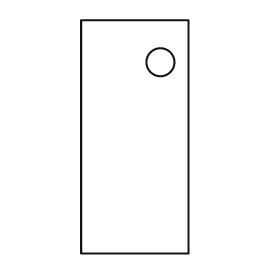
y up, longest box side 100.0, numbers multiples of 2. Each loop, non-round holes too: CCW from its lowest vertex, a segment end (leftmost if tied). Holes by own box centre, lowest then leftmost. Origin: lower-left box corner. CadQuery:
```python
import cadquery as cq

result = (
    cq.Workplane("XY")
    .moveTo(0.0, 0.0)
    .lineTo(46.0, 0.0)
    .lineTo(46.0, 100.0)
    .lineTo(0.0, 100.0)
    .close()
    .moveTo(34.0, 82.0)
    .circle(6.0)
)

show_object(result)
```